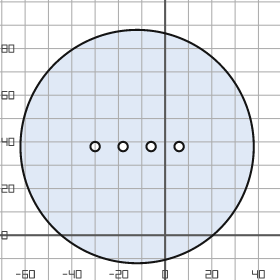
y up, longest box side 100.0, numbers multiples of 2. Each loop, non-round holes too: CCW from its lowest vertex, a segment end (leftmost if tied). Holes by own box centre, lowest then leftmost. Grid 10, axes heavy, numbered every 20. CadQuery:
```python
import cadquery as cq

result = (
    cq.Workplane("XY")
    .moveTo(-12.0, 38.0)
    .circle(50.0)
    .moveTo(-30.0, 38.0)
    .circle(2.0)
    .moveTo(-18.0, 38.0)
    .circle(2.0)
    .moveTo(-6.0, 38.0)
    .circle(2.0)
    .moveTo(6.0, 38.0)
    .circle(2.0)
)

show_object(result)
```